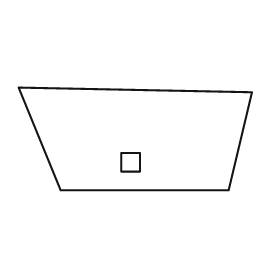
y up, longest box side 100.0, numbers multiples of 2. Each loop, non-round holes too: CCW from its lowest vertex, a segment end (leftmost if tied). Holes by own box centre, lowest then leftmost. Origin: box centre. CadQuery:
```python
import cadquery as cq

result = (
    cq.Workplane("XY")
    .moveTo(-32.0, -22.0)
    .lineTo(40.0, -22.0)
    .lineTo(50.0, 20.0)
    .lineTo(-50.0, 22.0)
    .close()
    .moveTo(-6.0, -14.0)
    .lineTo(2.0, -14.0)
    .lineTo(2.0, -6.0)
    .lineTo(-6.0, -6.0)
    .close()
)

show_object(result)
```